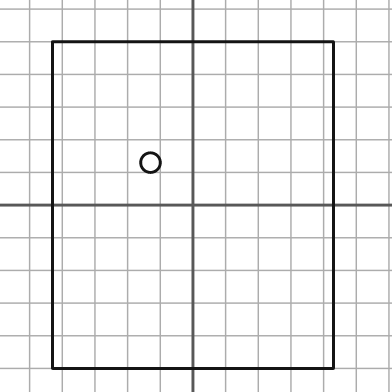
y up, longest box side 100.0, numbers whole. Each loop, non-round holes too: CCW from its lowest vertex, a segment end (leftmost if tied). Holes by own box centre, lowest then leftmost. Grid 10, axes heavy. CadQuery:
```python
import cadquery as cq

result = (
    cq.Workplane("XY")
    .moveTo(-43.0, -50.0)
    .lineTo(43.0, -50.0)
    .lineTo(43.0, 50.0)
    .lineTo(-43.0, 50.0)
    .close()
    .moveTo(-13.0, 13.0)
    .circle(3.0)
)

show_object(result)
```